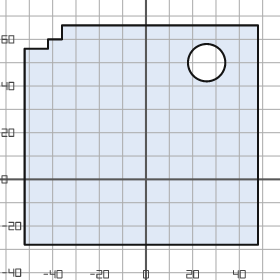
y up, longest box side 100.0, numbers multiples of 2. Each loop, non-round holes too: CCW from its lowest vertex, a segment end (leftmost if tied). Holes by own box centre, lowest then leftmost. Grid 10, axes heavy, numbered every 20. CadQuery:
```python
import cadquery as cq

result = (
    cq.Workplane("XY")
    .moveTo(-52.0, -28.0)
    .lineTo(48.0, -28.0)
    .lineTo(48.0, 66.0)
    .lineTo(-36.0, 66.0)
    .lineTo(-36.0, 60.0)
    .lineTo(-42.0, 60.0)
    .lineTo(-42.0, 56.0)
    .lineTo(-52.0, 56.0)
    .close()
    .moveTo(26.0, 50.0)
    .circle(8.0)
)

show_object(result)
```